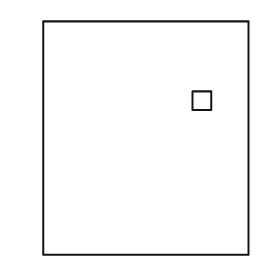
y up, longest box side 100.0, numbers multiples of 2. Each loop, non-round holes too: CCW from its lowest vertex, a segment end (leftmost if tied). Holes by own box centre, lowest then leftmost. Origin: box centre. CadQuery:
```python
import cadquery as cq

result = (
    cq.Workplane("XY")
    .moveTo(-44.0, -50.0)
    .lineTo(44.0, -50.0)
    .lineTo(44.0, 50.0)
    .lineTo(-44.0, 50.0)
    .close()
    .moveTo(20.0, 12.0)
    .lineTo(28.0, 12.0)
    .lineTo(28.0, 20.0)
    .lineTo(20.0, 20.0)
    .close()
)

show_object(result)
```